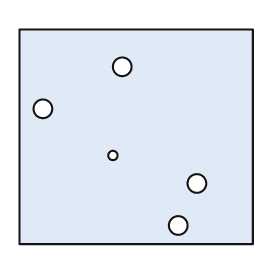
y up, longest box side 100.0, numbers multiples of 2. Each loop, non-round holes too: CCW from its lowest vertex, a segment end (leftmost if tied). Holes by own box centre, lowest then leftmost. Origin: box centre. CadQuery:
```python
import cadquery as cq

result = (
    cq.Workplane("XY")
    .moveTo(-50.0, -46.0)
    .lineTo(50.0, -46.0)
    .lineTo(50.0, 46.0)
    .lineTo(-50.0, 46.0)
    .close()
    .moveTo(18.0, -38.0)
    .circle(4.0)
    .moveTo(26.0, -20.0)
    .circle(4.0)
    .moveTo(-10.0, -8.0)
    .circle(2.0)
    .moveTo(-40.0, 12.0)
    .circle(4.0)
    .moveTo(-6.0, 30.0)
    .circle(4.0)
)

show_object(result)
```